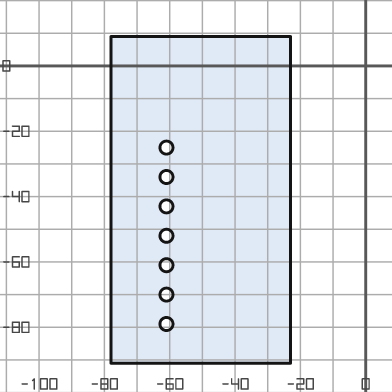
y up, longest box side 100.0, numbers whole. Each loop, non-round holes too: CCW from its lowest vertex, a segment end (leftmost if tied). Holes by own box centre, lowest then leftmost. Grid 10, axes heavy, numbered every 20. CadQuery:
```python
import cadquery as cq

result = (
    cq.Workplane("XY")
    .moveTo(-78.0, -91.0)
    .lineTo(-23.0, -91.0)
    .lineTo(-23.0, 9.0)
    .lineTo(-78.0, 9.0)
    .close()
    .moveTo(-61.0, -79.0)
    .circle(2.0)
    .moveTo(-61.0, -70.0)
    .circle(2.0)
    .moveTo(-61.0, -61.0)
    .circle(2.0)
    .moveTo(-61.0, -52.0)
    .circle(2.0)
    .moveTo(-61.0, -43.0)
    .circle(2.0)
    .moveTo(-61.0, -34.0)
    .circle(2.0)
    .moveTo(-61.0, -25.0)
    .circle(2.0)
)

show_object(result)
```